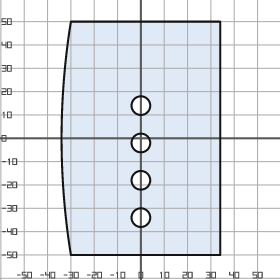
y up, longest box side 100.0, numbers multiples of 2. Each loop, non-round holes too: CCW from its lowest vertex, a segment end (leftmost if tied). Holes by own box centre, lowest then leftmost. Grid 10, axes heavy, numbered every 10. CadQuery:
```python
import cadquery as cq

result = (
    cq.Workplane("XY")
    .moveTo(-30.0, -50.0)
    .lineTo(34.0, -50.0)
    .lineTo(34.0, 50.0)
    .lineTo(-30.0, 50.0)
    .threePointArc((-34.0, 0.0), (-30.0, -50.0))
    .close()
    .moveTo(0.0, -34.0)
    .circle(4.0)
    .moveTo(0.0, -18.0)
    .circle(4.0)
    .moveTo(0.0, -2.0)
    .circle(4.0)
    .moveTo(0.0, 14.0)
    .circle(4.0)
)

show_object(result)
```